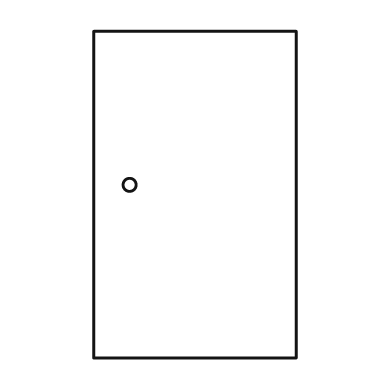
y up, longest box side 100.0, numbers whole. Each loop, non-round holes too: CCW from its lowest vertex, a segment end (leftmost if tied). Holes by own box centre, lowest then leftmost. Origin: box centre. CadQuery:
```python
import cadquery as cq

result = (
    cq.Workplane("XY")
    .moveTo(-31.0, -50.0)
    .lineTo(31.0, -50.0)
    .lineTo(31.0, 50.0)
    .lineTo(-31.0, 50.0)
    .close()
    .moveTo(-20.0, 3.0)
    .circle(2.0)
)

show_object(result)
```